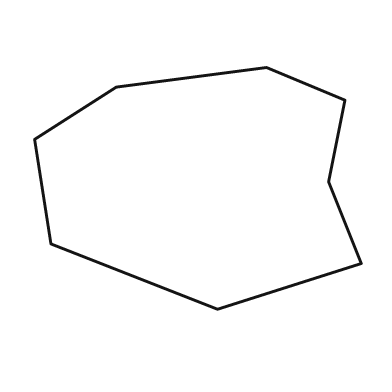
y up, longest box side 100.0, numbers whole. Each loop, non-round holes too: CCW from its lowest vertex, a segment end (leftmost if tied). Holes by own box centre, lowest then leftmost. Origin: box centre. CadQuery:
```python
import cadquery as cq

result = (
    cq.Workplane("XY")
    .moveTo(6.0, -37.0)
    .lineTo(50.0, -23.0)
    .lineTo(40.0, 2.0)
    .lineTo(45.0, 27.0)
    .lineTo(21.0, 37.0)
    .lineTo(-25.0, 31.0)
    .lineTo(-50.0, 15.0)
    .lineTo(-45.0, -17.0)
    .close()
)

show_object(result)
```